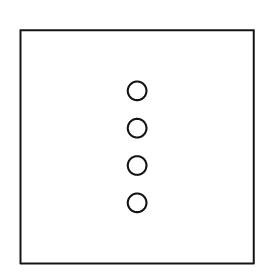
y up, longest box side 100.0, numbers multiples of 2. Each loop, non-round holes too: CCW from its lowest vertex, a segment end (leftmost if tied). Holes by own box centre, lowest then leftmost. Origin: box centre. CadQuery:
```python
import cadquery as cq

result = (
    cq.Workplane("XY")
    .moveTo(-50.0, -50.0)
    .lineTo(50.0, -50.0)
    .lineTo(50.0, 50.0)
    .lineTo(-50.0, 50.0)
    .close()
    .moveTo(0.0, -24.0)
    .circle(4.0)
    .moveTo(0.0, -8.0)
    .circle(4.0)
    .moveTo(0.0, 8.0)
    .circle(4.0)
    .moveTo(0.0, 24.0)
    .circle(4.0)
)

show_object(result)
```